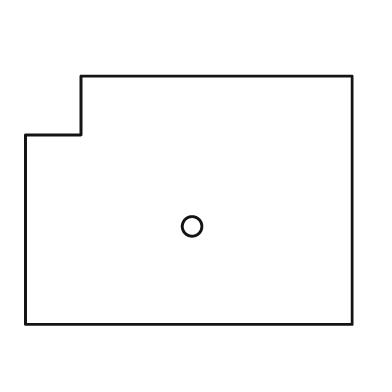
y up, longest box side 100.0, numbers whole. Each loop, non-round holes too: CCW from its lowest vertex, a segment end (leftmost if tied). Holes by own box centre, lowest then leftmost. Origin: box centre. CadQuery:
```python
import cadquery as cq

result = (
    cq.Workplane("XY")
    .moveTo(-50.0, -38.0)
    .lineTo(50.0, -38.0)
    .lineTo(50.0, 38.0)
    .lineTo(-33.0, 38.0)
    .lineTo(-33.0, 20.0)
    .lineTo(-50.0, 20.0)
    .close()
    .moveTo(1.0, -8.0)
    .circle(3.0)
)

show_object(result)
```